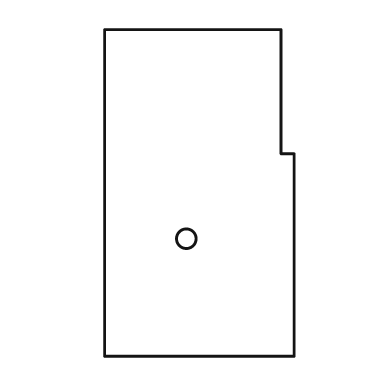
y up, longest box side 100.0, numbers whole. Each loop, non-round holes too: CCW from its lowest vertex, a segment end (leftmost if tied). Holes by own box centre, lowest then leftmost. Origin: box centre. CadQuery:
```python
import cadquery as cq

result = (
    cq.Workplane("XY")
    .moveTo(-29.0, -50.0)
    .lineTo(29.0, -50.0)
    .lineTo(29.0, 12.0)
    .lineTo(25.0, 12.0)
    .lineTo(25.0, 50.0)
    .lineTo(-29.0, 50.0)
    .close()
    .moveTo(-4.0, -14.0)
    .circle(3.0)
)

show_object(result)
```